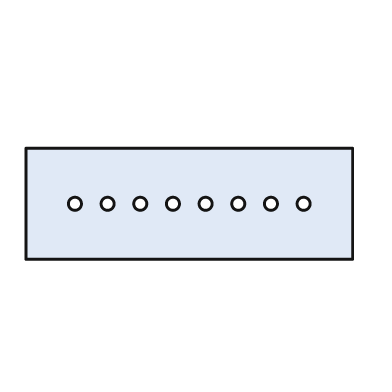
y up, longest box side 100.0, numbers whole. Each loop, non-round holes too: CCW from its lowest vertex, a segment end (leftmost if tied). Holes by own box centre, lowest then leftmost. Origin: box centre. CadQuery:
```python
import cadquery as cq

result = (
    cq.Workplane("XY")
    .moveTo(-50.0, -17.0)
    .lineTo(50.0, -17.0)
    .lineTo(50.0, 17.0)
    .lineTo(-50.0, 17.0)
    .close()
    .moveTo(-35.0, 0.0)
    .circle(2.0)
    .moveTo(-25.0, 0.0)
    .circle(2.0)
    .moveTo(-15.0, 0.0)
    .circle(2.0)
    .moveTo(-5.0, 0.0)
    .circle(2.0)
    .moveTo(5.0, 0.0)
    .circle(2.0)
    .moveTo(15.0, 0.0)
    .circle(2.0)
    .moveTo(25.0, 0.0)
    .circle(2.0)
    .moveTo(35.0, 0.0)
    .circle(2.0)
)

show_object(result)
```